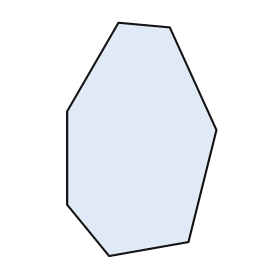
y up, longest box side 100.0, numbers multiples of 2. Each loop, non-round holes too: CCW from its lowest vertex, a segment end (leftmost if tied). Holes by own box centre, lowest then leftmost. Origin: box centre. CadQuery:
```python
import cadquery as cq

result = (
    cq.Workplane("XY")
    .moveTo(-14.0, -50.0)
    .lineTo(20.0, -44.0)
    .lineTo(32.0, 4.0)
    .lineTo(12.0, 48.0)
    .lineTo(-10.0, 50.0)
    .lineTo(-32.0, 12.0)
    .lineTo(-32.0, -28.0)
    .close()
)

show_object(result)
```